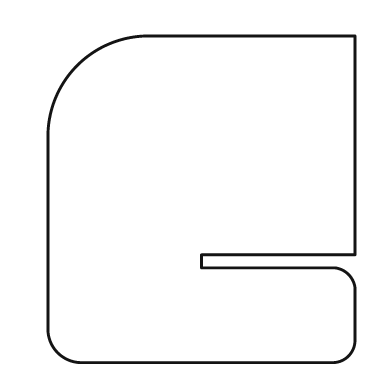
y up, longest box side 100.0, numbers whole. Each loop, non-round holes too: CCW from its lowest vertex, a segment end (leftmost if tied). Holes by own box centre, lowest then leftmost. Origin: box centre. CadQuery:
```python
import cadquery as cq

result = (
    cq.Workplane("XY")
    .moveTo(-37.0, -50.0)
    .lineTo(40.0, -50.0)
    .threePointArc((45.0, -48.0), (47.0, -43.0))
    .lineTo(47.0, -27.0)
    .threePointArc((45.0, -23.0), (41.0, -21.0))
    .lineTo(0.0, -21.0)
    .lineTo(0.0, -17.0)
    .lineTo(47.0, -17.0)
    .lineTo(47.0, 50.0)
    .lineTo(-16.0, 50.0)
    .threePointArc((-38.0, 41.0), (-47.0, 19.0))
    .lineTo(-47.0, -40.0)
    .threePointArc((-44.0, -47.0), (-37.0, -50.0))
    .close()
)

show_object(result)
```